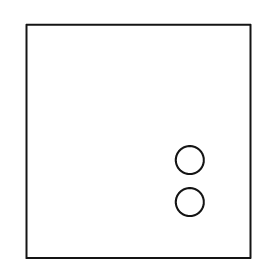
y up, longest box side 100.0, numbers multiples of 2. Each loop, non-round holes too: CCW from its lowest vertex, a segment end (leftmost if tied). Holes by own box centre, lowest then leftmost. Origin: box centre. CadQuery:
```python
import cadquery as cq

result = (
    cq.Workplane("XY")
    .moveTo(-48.0, -50.0)
    .lineTo(48.0, -50.0)
    .lineTo(48.0, 50.0)
    .lineTo(-48.0, 50.0)
    .close()
    .moveTo(22.0, -26.0)
    .circle(6.0)
    .moveTo(22.0, -8.0)
    .circle(6.0)
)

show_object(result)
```